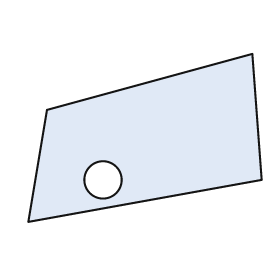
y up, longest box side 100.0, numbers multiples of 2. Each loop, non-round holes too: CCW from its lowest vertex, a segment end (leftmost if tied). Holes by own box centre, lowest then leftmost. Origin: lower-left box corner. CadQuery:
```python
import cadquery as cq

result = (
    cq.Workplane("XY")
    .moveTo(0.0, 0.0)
    .lineTo(100.0, 18.0)
    .lineTo(96.0, 72.0)
    .lineTo(8.0, 48.0)
    .close()
    .moveTo(32.0, 18.0)
    .circle(8.0)
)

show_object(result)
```